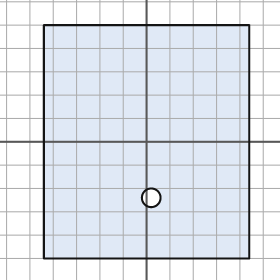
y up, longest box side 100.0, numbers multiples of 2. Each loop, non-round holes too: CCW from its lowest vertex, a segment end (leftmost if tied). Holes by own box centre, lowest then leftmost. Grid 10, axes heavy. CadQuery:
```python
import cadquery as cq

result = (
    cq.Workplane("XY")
    .moveTo(-44.0, -50.0)
    .lineTo(44.0, -50.0)
    .lineTo(44.0, 50.0)
    .lineTo(-44.0, 50.0)
    .close()
    .moveTo(2.0, -24.0)
    .circle(4.0)
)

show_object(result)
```